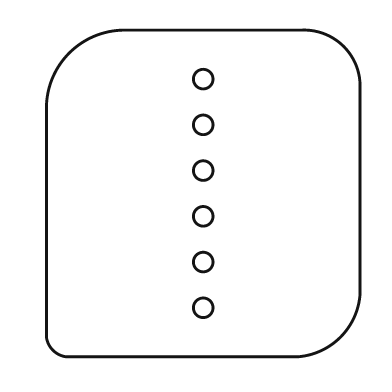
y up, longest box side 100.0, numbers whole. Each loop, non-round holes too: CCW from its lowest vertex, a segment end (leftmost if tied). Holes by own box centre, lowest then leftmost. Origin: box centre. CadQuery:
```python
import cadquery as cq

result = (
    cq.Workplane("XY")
    .moveTo(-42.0, -50.0)
    .lineTo(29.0, -50.0)
    .threePointArc((42.0, -44.0), (48.0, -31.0))
    .lineTo(48.0, 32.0)
    .threePointArc((43.0, 45.0), (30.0, 50.0))
    .lineTo(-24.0, 50.0)
    .threePointArc((-41.0, 43.0), (-48.0, 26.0))
    .lineTo(-48.0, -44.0)
    .threePointArc((-46.0, -48.0), (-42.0, -50.0))
    .close()
    .moveTo(0.0, -35.0)
    .circle(3.0)
    .moveTo(0.0, -21.0)
    .circle(3.0)
    .moveTo(0.0, -7.0)
    .circle(3.0)
    .moveTo(0.0, 7.0)
    .circle(3.0)
    .moveTo(0.0, 21.0)
    .circle(3.0)
    .moveTo(0.0, 35.0)
    .circle(3.0)
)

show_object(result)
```